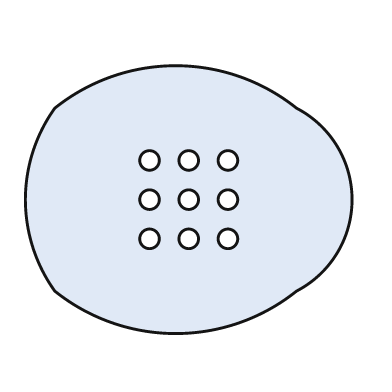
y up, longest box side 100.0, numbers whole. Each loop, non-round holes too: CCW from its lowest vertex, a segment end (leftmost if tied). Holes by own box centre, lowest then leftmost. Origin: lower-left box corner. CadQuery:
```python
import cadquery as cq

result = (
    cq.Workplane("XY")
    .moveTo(9.0, 13.0)
    .threePointArc((46.0, 0.0), (83.0, 13.0))
    .threePointArc((100.0, 41.0), (83.0, 69.0))
    .threePointArc((46.0, 82.0), (9.0, 69.0))
    .threePointArc((0.0, 41.0), (9.0, 13.0))
    .close()
    .moveTo(38.0, 29.0)
    .circle(3.0)
    .moveTo(50.0, 29.0)
    .circle(3.0)
    .moveTo(62.0, 29.0)
    .circle(3.0)
    .moveTo(38.0, 41.0)
    .circle(3.0)
    .moveTo(50.0, 41.0)
    .circle(3.0)
    .moveTo(62.0, 41.0)
    .circle(3.0)
    .moveTo(38.0, 53.0)
    .circle(3.0)
    .moveTo(50.0, 53.0)
    .circle(3.0)
    .moveTo(62.0, 53.0)
    .circle(3.0)
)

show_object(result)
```